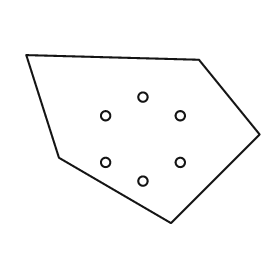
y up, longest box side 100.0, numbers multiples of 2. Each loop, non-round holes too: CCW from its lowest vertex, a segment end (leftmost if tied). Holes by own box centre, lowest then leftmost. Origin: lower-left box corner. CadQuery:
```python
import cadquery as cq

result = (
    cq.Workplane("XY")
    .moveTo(62.0, 0.0)
    .lineTo(100.0, 38.0)
    .lineTo(74.0, 70.0)
    .lineTo(0.0, 72.0)
    .lineTo(14.0, 28.0)
    .close()
    .moveTo(50.0, 18.0)
    .circle(2.0)
    .moveTo(34.0, 26.0)
    .circle(2.0)
    .moveTo(66.0, 26.0)
    .circle(2.0)
    .moveTo(34.0, 46.0)
    .circle(2.0)
    .moveTo(66.0, 46.0)
    .circle(2.0)
    .moveTo(50.0, 54.0)
    .circle(2.0)
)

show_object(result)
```